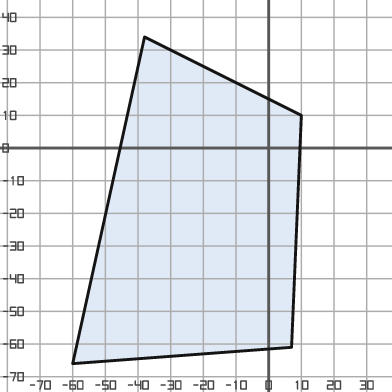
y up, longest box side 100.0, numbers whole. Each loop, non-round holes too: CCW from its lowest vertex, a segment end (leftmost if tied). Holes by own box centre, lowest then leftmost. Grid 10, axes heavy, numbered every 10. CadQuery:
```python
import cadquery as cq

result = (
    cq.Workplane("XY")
    .moveTo(-60.0, -66.0)
    .lineTo(7.0, -61.0)
    .lineTo(10.0, 10.0)
    .lineTo(-38.0, 34.0)
    .close()
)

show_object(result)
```